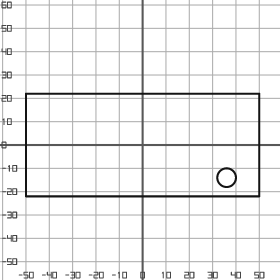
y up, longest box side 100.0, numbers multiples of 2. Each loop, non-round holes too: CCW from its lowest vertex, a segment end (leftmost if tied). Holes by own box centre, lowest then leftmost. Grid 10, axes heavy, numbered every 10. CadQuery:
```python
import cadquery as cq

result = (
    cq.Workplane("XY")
    .moveTo(-50.0, -22.0)
    .lineTo(50.0, -22.0)
    .lineTo(50.0, 22.0)
    .lineTo(-50.0, 22.0)
    .close()
    .moveTo(36.0, -14.0)
    .circle(4.0)
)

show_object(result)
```